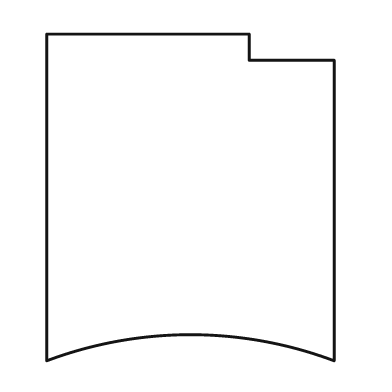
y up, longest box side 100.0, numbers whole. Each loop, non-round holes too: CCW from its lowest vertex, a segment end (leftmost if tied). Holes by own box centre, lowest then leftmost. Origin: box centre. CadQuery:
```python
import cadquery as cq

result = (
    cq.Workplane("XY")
    .moveTo(-44.0, -50.0)
    .threePointArc((0.0, -42.0), (44.0, -50.0))
    .lineTo(44.0, 42.0)
    .lineTo(18.0, 42.0)
    .lineTo(18.0, 50.0)
    .lineTo(-44.0, 50.0)
    .close()
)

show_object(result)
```